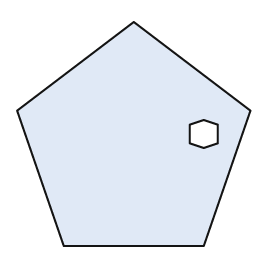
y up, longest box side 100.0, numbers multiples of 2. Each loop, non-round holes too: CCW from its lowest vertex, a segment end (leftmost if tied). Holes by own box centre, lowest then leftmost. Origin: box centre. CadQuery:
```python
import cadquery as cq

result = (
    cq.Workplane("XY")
    .moveTo(-30.0, -48.0)
    .lineTo(30.0, -48.0)
    .lineTo(50.0, 10.0)
    .lineTo(0.0, 48.0)
    .lineTo(-50.0, 10.0)
    .close()
    .moveTo(30.0, -6.0)
    .lineTo(36.0, -4.0)
    .lineTo(36.0, 4.0)
    .lineTo(30.0, 6.0)
    .lineTo(24.0, 4.0)
    .lineTo(24.0, -4.0)
    .close()
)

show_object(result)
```